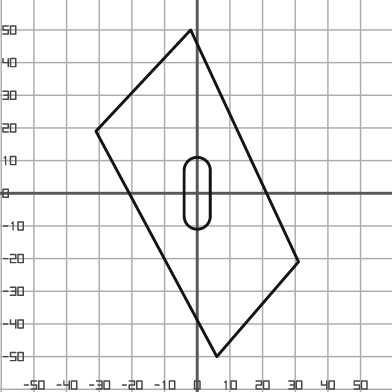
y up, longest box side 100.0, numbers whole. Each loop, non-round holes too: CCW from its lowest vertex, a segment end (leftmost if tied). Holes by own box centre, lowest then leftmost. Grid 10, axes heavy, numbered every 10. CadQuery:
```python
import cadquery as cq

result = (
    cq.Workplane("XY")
    .moveTo(6.0, -50.0)
    .lineTo(31.0, -21.0)
    .lineTo(-2.0, 50.0)
    .lineTo(-31.0, 19.0)
    .close()
    .moveTo(-4.0, -7.0)
    .threePointArc((0.0, -11.0), (4.0, -7.0))
    .lineTo(4.0, 7.0)
    .threePointArc((0.0, 11.0), (-4.0, 7.0))
    .close()
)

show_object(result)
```